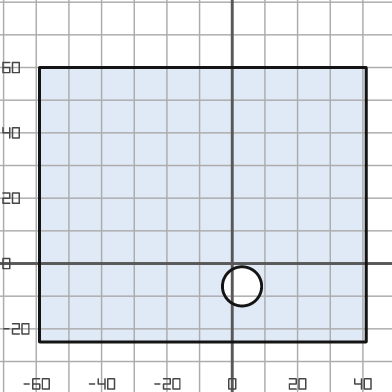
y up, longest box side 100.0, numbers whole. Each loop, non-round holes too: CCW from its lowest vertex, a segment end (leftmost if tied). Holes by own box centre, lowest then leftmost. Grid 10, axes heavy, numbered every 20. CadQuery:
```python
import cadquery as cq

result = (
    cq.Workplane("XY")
    .moveTo(-59.0, -24.0)
    .lineTo(41.0, -24.0)
    .lineTo(41.0, 60.0)
    .lineTo(-59.0, 60.0)
    .close()
    .moveTo(3.0, -7.0)
    .circle(6.0)
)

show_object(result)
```